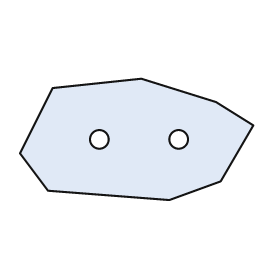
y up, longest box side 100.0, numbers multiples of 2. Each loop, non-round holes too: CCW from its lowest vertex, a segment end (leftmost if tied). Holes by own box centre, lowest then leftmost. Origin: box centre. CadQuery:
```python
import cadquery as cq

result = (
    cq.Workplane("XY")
    .moveTo(14.0, -26.0)
    .lineTo(36.0, -18.0)
    .lineTo(50.0, 6.0)
    .lineTo(34.0, 16.0)
    .lineTo(2.0, 26.0)
    .lineTo(-36.0, 22.0)
    .lineTo(-50.0, -6.0)
    .lineTo(-38.0, -22.0)
    .close()
    .moveTo(-16.0, 0.0)
    .circle(4.0)
    .moveTo(18.0, 0.0)
    .circle(4.0)
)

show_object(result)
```